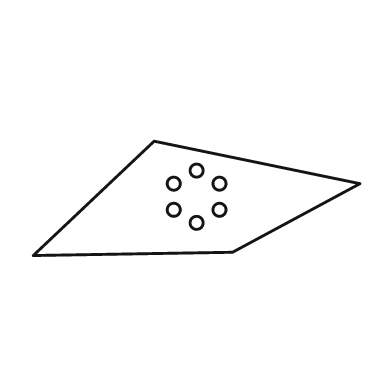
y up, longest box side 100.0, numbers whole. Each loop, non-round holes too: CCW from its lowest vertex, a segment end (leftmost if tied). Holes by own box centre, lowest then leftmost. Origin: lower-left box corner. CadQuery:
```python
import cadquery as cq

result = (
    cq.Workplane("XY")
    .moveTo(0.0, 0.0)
    .lineTo(61.0, 1.0)
    .lineTo(100.0, 22.0)
    .lineTo(37.0, 35.0)
    .close()
    .moveTo(50.0, 10.0)
    .circle(2.0)
    .moveTo(43.0, 14.0)
    .circle(2.0)
    .moveTo(57.0, 14.0)
    .circle(2.0)
    .moveTo(43.0, 22.0)
    .circle(2.0)
    .moveTo(57.0, 22.0)
    .circle(2.0)
    .moveTo(50.0, 26.0)
    .circle(2.0)
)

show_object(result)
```